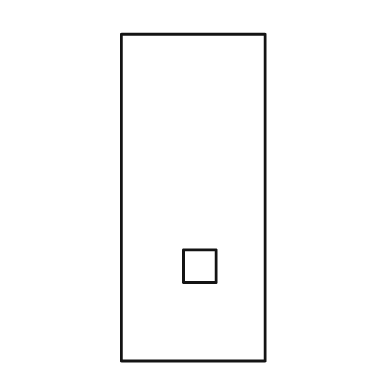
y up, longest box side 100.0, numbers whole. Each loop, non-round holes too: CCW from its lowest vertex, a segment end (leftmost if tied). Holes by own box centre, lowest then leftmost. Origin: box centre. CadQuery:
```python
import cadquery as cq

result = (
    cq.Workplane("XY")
    .moveTo(-22.0, -50.0)
    .lineTo(22.0, -50.0)
    .lineTo(22.0, 50.0)
    .lineTo(-22.0, 50.0)
    .close()
    .moveTo(-3.0, -26.0)
    .lineTo(7.0, -26.0)
    .lineTo(7.0, -16.0)
    .lineTo(-3.0, -16.0)
    .close()
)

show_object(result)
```